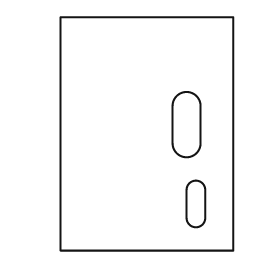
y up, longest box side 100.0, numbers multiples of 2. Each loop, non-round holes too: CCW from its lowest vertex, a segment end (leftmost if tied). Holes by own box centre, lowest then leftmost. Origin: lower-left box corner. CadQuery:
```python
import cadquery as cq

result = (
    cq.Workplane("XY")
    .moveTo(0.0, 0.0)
    .lineTo(74.0, 0.0)
    .lineTo(74.0, 100.0)
    .lineTo(0.0, 100.0)
    .close()
    .moveTo(54.0, 14.0)
    .threePointArc((58.0, 10.0), (62.0, 14.0))
    .lineTo(62.0, 26.0)
    .threePointArc((58.0, 30.0), (54.0, 26.0))
    .close()
    .moveTo(48.0, 46.0)
    .threePointArc((54.0, 40.0), (60.0, 46.0))
    .lineTo(60.0, 62.0)
    .threePointArc((54.0, 68.0), (48.0, 62.0))
    .close()
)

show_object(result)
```